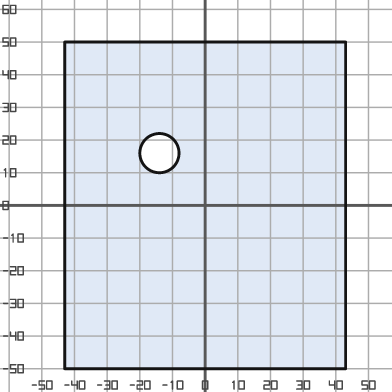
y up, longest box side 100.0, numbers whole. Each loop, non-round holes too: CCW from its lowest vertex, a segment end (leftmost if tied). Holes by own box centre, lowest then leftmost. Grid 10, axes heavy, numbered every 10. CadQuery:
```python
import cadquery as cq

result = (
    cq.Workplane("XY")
    .moveTo(-43.0, -50.0)
    .lineTo(43.0, -50.0)
    .lineTo(43.0, 50.0)
    .lineTo(-43.0, 50.0)
    .close()
    .moveTo(-14.0, 16.0)
    .circle(6.0)
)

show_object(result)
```